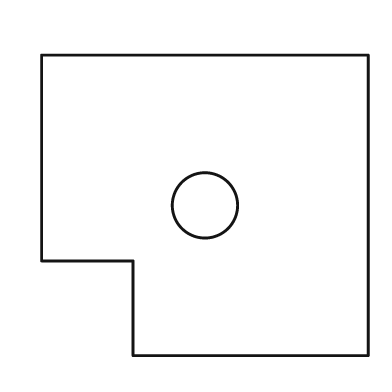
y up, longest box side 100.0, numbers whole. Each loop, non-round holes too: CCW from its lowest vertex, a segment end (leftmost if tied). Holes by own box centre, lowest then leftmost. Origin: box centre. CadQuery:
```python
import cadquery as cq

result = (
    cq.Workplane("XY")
    .moveTo(-22.0, -46.0)
    .lineTo(50.0, -46.0)
    .lineTo(50.0, 46.0)
    .lineTo(-50.0, 46.0)
    .lineTo(-50.0, -17.0)
    .lineTo(-22.0, -17.0)
    .close()
    .moveTo(0.0, 0.0)
    .circle(10.0)
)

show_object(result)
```